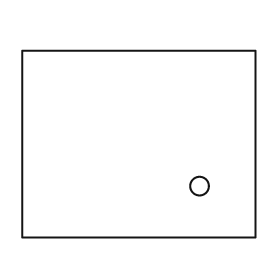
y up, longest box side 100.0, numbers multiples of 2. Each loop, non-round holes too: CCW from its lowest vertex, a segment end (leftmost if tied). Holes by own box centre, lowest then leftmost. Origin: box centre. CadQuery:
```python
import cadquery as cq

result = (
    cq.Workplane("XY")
    .moveTo(-50.0, -40.0)
    .lineTo(50.0, -40.0)
    .lineTo(50.0, 40.0)
    .lineTo(-50.0, 40.0)
    .close()
    .moveTo(26.0, -18.0)
    .circle(4.0)
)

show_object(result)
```